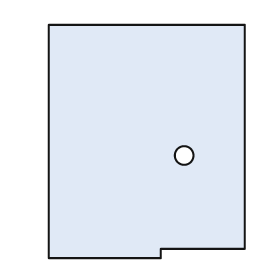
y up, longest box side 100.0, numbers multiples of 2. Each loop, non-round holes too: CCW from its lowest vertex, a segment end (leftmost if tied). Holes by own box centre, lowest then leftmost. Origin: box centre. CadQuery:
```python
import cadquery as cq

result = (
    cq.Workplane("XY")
    .moveTo(-42.0, -50.0)
    .lineTo(6.0, -50.0)
    .lineTo(6.0, -46.0)
    .lineTo(42.0, -46.0)
    .lineTo(42.0, 50.0)
    .lineTo(-42.0, 50.0)
    .close()
    .moveTo(16.0, -6.0)
    .circle(4.0)
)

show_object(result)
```